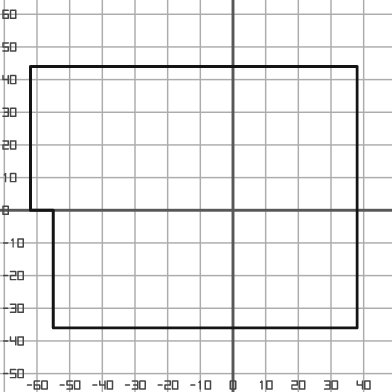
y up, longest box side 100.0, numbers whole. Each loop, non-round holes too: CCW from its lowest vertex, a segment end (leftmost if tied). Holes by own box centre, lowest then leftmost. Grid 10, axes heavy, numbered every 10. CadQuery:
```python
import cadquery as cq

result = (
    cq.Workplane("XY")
    .moveTo(-55.0, -36.0)
    .lineTo(38.0, -36.0)
    .lineTo(38.0, 44.0)
    .lineTo(-62.0, 44.0)
    .lineTo(-62.0, 0.0)
    .lineTo(-55.0, 0.0)
    .close()
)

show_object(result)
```